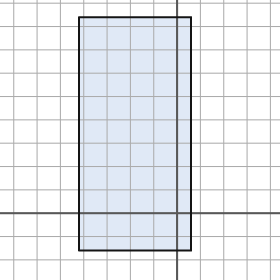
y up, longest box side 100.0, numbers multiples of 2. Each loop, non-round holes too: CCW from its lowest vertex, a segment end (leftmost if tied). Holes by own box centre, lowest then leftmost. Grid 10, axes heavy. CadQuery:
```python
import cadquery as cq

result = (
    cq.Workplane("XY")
    .moveTo(-42.0, -16.0)
    .lineTo(6.0, -16.0)
    .lineTo(6.0, 84.0)
    .lineTo(-42.0, 84.0)
    .close()
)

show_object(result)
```